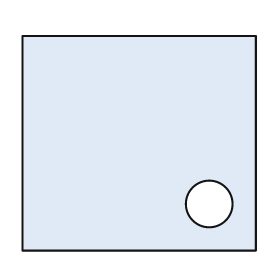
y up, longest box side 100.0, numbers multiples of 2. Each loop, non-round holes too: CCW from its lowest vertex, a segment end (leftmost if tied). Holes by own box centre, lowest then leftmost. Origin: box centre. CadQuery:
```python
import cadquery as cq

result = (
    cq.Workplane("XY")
    .moveTo(-50.0, -46.0)
    .lineTo(50.0, -46.0)
    .lineTo(50.0, 46.0)
    .lineTo(-50.0, 46.0)
    .close()
    .moveTo(30.0, -26.0)
    .circle(10.0)
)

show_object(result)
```